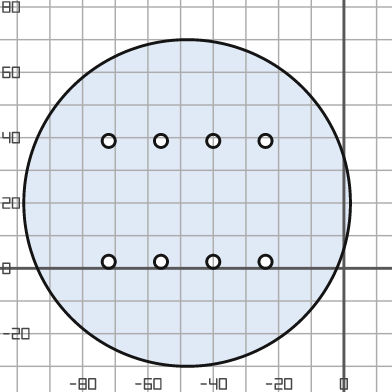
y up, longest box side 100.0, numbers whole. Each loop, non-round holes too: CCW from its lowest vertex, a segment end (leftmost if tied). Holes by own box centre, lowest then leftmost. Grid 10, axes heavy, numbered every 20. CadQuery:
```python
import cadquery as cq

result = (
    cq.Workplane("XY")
    .moveTo(-48.0, 20.0)
    .circle(50.0)
    .moveTo(-72.0, 2.0)
    .circle(2.0)
    .moveTo(-56.0, 2.0)
    .circle(2.0)
    .moveTo(-40.0, 2.0)
    .circle(2.0)
    .moveTo(-24.0, 2.0)
    .circle(2.0)
    .moveTo(-72.0, 39.0)
    .circle(2.0)
    .moveTo(-56.0, 39.0)
    .circle(2.0)
    .moveTo(-40.0, 39.0)
    .circle(2.0)
    .moveTo(-24.0, 39.0)
    .circle(2.0)
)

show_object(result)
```